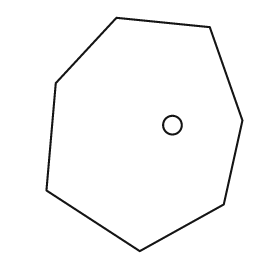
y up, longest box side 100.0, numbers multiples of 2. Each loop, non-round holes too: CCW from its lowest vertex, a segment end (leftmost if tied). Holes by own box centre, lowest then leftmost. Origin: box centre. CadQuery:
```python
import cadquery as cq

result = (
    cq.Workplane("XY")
    .moveTo(-2.0, -50.0)
    .lineTo(34.0, -30.0)
    .lineTo(42.0, 6.0)
    .lineTo(28.0, 46.0)
    .lineTo(-12.0, 50.0)
    .lineTo(-38.0, 22.0)
    .lineTo(-42.0, -24.0)
    .close()
    .moveTo(12.0, 4.0)
    .circle(4.0)
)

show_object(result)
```